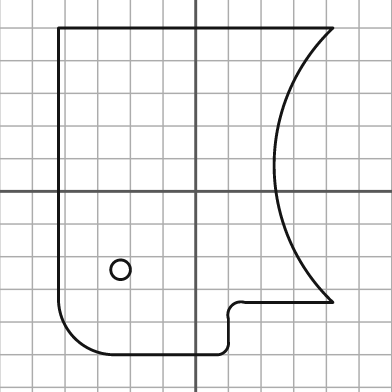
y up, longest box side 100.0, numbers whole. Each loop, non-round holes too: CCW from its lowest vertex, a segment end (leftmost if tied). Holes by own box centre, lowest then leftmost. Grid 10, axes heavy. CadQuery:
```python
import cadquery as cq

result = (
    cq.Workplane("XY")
    .moveTo(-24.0, -50.0)
    .lineTo(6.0, -50.0)
    .threePointArc((9.0, -49.0), (10.0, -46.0))
    .lineTo(10.0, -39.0)
    .threePointArc((11.0, -35.0), (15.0, -34.0))
    .lineTo(42.0, -34.0)
    .threePointArc((24.0, 8.0), (42.0, 50.0))
    .lineTo(-42.0, 50.0)
    .lineTo(-42.0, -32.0)
    .threePointArc((-37.0, -45.0), (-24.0, -50.0))
    .close()
    .moveTo(-23.0, -24.0)
    .circle(3.0)
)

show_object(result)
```